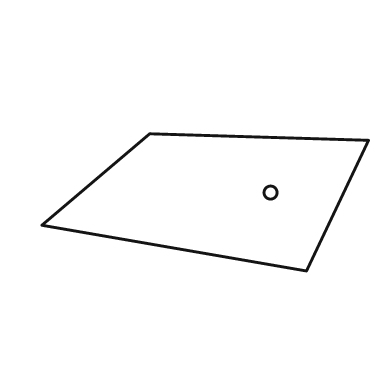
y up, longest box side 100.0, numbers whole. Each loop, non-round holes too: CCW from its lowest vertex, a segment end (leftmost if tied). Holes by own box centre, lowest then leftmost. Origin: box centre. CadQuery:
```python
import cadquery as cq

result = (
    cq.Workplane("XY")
    .moveTo(31.0, -21.0)
    .lineTo(50.0, 19.0)
    .lineTo(-17.0, 21.0)
    .lineTo(-50.0, -7.0)
    .close()
    .moveTo(20.0, 3.0)
    .circle(2.0)
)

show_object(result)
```